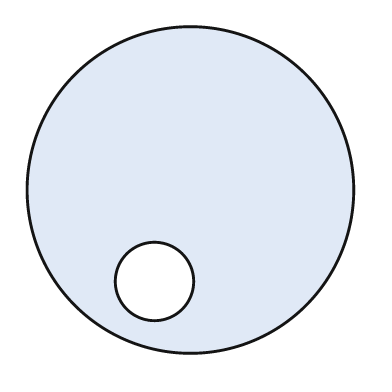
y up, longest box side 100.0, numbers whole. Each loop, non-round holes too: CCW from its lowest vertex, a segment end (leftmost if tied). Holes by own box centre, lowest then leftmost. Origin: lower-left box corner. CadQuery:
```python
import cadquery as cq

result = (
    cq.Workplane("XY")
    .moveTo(50.0, 50.0)
    .circle(50.0)
    .moveTo(39.0, 22.0)
    .circle(12.0)
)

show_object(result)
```